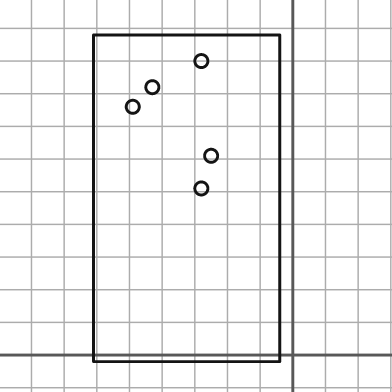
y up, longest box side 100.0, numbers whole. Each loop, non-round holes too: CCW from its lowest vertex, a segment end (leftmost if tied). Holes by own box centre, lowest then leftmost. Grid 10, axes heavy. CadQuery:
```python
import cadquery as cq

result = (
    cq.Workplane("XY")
    .moveTo(-61.0, -2.0)
    .lineTo(-4.0, -2.0)
    .lineTo(-4.0, 98.0)
    .lineTo(-61.0, 98.0)
    .close()
    .moveTo(-28.0, 51.0)
    .circle(2.0)
    .moveTo(-25.0, 61.0)
    .circle(2.0)
    .moveTo(-49.0, 76.0)
    .circle(2.0)
    .moveTo(-43.0, 82.0)
    .circle(2.0)
    .moveTo(-28.0, 90.0)
    .circle(2.0)
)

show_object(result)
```